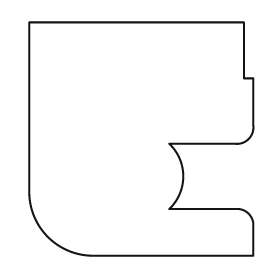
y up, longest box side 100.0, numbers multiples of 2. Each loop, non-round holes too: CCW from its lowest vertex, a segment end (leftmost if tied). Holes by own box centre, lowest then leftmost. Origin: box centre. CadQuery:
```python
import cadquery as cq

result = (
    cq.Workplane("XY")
    .moveTo(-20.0, -50.0)
    .lineTo(48.0, -50.0)
    .lineTo(48.0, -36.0)
    .threePointArc((46.0, -32.0), (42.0, -30.0))
    .lineTo(12.0, -30.0)
    .threePointArc((18.0, -16.0), (12.0, -2.0))
    .lineTo(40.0, -2.0)
    .threePointArc((46.0, 0.0), (48.0, 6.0))
    .lineTo(48.0, 26.0)
    .lineTo(44.0, 26.0)
    .lineTo(44.0, 50.0)
    .lineTo(-48.0, 50.0)
    .lineTo(-48.0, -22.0)
    .threePointArc((-40.0, -42.0), (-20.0, -50.0))
    .close()
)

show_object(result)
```